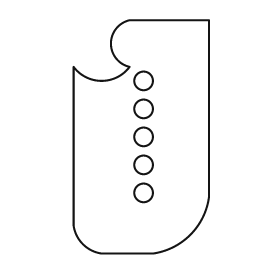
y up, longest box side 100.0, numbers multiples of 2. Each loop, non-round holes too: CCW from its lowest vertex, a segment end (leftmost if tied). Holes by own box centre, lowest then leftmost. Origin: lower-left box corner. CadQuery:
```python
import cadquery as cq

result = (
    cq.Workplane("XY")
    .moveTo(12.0, 0.0)
    .lineTo(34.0, 0.0)
    .threePointArc((50.0, 8.0), (58.0, 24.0))
    .lineTo(58.0, 100.0)
    .lineTo(24.0, 100.0)
    .threePointArc((16.0, 90.0), (24.0, 80.0))
    .threePointArc((12.0, 74.0), (0.0, 80.0))
    .lineTo(0.0, 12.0)
    .threePointArc((4.0, 4.0), (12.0, 0.0))
    .close()
    .moveTo(30.0, 26.0)
    .circle(4.0)
    .moveTo(30.0, 38.0)
    .circle(4.0)
    .moveTo(30.0, 50.0)
    .circle(4.0)
    .moveTo(30.0, 62.0)
    .circle(4.0)
    .moveTo(30.0, 74.0)
    .circle(4.0)
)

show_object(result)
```